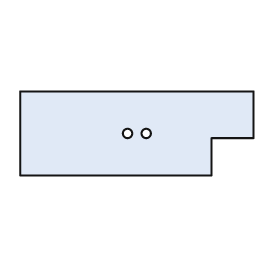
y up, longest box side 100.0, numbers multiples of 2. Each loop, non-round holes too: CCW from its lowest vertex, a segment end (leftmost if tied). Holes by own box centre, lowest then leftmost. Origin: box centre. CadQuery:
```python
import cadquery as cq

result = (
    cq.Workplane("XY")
    .moveTo(-50.0, -18.0)
    .lineTo(32.0, -18.0)
    .lineTo(32.0, -2.0)
    .lineTo(50.0, -2.0)
    .lineTo(50.0, 18.0)
    .lineTo(-50.0, 18.0)
    .close()
    .moveTo(-4.0, 0.0)
    .circle(2.0)
    .moveTo(4.0, 0.0)
    .circle(2.0)
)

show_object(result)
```